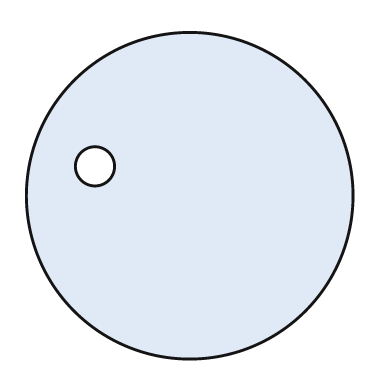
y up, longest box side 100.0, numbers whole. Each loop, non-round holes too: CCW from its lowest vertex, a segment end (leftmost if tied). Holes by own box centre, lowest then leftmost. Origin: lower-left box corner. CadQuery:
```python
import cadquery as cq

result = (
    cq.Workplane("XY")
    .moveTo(50.0, 50.0)
    .circle(50.0)
    .moveTo(21.0, 59.0)
    .circle(6.0)
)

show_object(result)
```